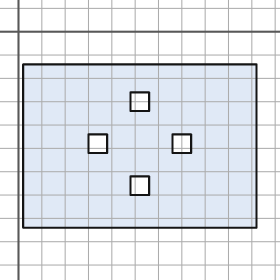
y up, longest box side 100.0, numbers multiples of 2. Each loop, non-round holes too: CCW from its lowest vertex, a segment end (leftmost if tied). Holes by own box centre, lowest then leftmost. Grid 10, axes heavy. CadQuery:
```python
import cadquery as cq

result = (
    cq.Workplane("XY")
    .moveTo(2.0, -84.0)
    .lineTo(102.0, -84.0)
    .lineTo(102.0, -14.0)
    .lineTo(2.0, -14.0)
    .close()
    .moveTo(48.0, -70.0)
    .lineTo(56.0, -70.0)
    .lineTo(56.0, -62.0)
    .lineTo(48.0, -62.0)
    .close()
    .moveTo(30.0, -52.0)
    .lineTo(38.0, -52.0)
    .lineTo(38.0, -44.0)
    .lineTo(30.0, -44.0)
    .close()
    .moveTo(66.0, -52.0)
    .lineTo(74.0, -52.0)
    .lineTo(74.0, -44.0)
    .lineTo(66.0, -44.0)
    .close()
    .moveTo(48.0, -34.0)
    .lineTo(56.0, -34.0)
    .lineTo(56.0, -26.0)
    .lineTo(48.0, -26.0)
    .close()
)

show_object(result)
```